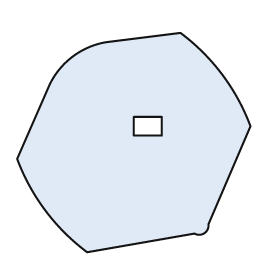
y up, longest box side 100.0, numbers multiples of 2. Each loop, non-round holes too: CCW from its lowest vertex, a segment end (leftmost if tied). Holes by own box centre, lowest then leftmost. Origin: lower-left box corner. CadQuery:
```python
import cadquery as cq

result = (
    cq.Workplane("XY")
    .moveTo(30.0, 0.0)
    .lineTo(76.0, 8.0)
    .threePointArc((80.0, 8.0), (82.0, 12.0))
    .lineTo(100.0, 54.0)
    .threePointArc((88.0, 76.0), (70.0, 94.0))
    .lineTo(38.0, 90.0)
    .threePointArc((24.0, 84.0), (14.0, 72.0))
    .lineTo(0.0, 40.0)
    .threePointArc((12.0, 18.0), (30.0, 0.0))
    .close()
    .moveTo(50.0, 50.0)
    .lineTo(62.0, 50.0)
    .lineTo(62.0, 58.0)
    .lineTo(50.0, 58.0)
    .close()
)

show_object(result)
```